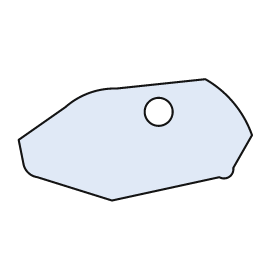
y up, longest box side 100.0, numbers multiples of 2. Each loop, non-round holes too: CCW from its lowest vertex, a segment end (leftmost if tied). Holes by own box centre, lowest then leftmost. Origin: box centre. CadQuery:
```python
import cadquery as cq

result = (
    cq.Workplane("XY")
    .moveTo(-10.0, -26.0)
    .lineTo(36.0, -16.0)
    .threePointArc((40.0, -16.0), (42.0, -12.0))
    .lineTo(50.0, 2.0)
    .threePointArc((42.0, 16.0), (30.0, 26.0))
    .lineTo(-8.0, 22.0)
    .threePointArc((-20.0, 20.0), (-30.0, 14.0))
    .lineTo(-50.0, 0.0)
    .lineTo(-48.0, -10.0)
    .threePointArc((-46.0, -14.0), (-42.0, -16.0))
    .close()
    .moveTo(10.0, 12.0)
    .circle(6.0)
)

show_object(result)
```